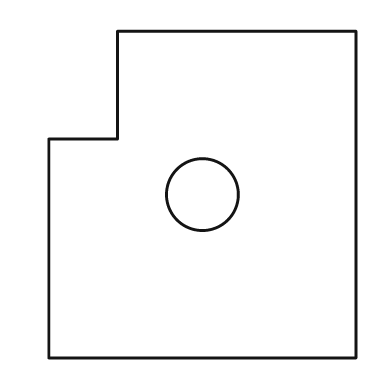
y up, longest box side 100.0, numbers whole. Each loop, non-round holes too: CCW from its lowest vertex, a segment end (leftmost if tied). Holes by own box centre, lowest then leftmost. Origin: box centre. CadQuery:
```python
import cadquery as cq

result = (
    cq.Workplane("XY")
    .moveTo(-47.0, -50.0)
    .lineTo(47.0, -50.0)
    .lineTo(47.0, 50.0)
    .lineTo(-26.0, 50.0)
    .lineTo(-26.0, 17.0)
    .lineTo(-47.0, 17.0)
    .close()
    .moveTo(0.0, 0.0)
    .circle(11.0)
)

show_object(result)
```